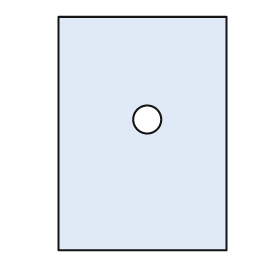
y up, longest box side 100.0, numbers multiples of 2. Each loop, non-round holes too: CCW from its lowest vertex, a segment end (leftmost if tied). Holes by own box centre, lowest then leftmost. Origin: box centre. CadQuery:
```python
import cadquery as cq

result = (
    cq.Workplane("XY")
    .moveTo(-36.0, -50.0)
    .lineTo(36.0, -50.0)
    .lineTo(36.0, 50.0)
    .lineTo(-36.0, 50.0)
    .close()
    .moveTo(2.0, 6.0)
    .circle(6.0)
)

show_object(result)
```